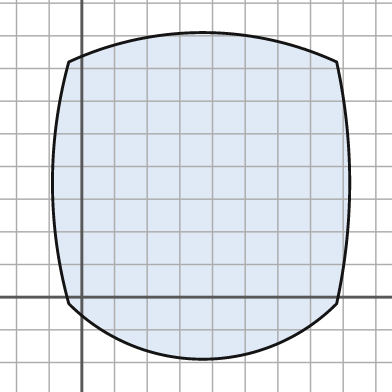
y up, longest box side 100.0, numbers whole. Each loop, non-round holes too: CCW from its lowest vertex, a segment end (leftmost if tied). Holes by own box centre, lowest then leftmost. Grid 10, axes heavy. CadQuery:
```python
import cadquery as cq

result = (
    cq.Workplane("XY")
    .moveTo(-4.0, -2.0)
    .threePointArc((37.0, -19.0), (78.0, -2.0))
    .threePointArc((82.0, 35.0), (78.0, 72.0))
    .threePointArc((37.0, 81.0), (-4.0, 72.0))
    .threePointArc((-9.0, 35.0), (-4.0, -2.0))
    .close()
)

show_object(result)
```